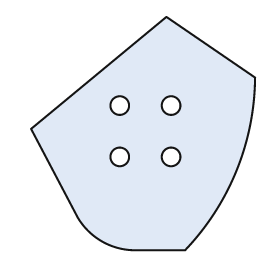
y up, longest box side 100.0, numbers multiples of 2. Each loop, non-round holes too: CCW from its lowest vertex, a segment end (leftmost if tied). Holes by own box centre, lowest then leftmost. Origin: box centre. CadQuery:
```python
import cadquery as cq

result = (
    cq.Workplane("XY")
    .moveTo(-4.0, -50.0)
    .lineTo(18.0, -50.0)
    .threePointArc((40.0, -16.0), (48.0, 24.0))
    .lineTo(10.0, 50.0)
    .lineTo(-48.0, 2.0)
    .lineTo(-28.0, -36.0)
    .threePointArc((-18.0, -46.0), (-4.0, -50.0))
    .close()
    .moveTo(-10.0, -10.0)
    .circle(4.0)
    .moveTo(12.0, -10.0)
    .circle(4.0)
    .moveTo(-10.0, 12.0)
    .circle(4.0)
    .moveTo(12.0, 12.0)
    .circle(4.0)
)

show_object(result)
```